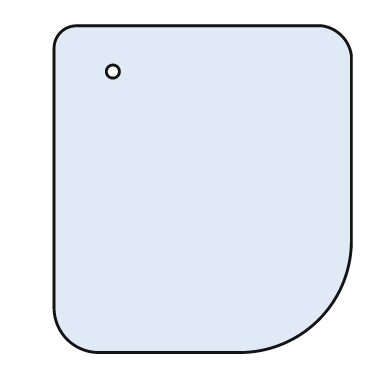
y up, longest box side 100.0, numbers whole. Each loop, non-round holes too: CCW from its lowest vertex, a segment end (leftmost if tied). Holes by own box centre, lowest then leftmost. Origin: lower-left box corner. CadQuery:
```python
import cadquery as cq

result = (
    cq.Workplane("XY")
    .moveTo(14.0, 0.0)
    .lineTo(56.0, 0.0)
    .threePointArc((81.0, 10.0), (91.0, 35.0))
    .lineTo(91.0, 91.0)
    .threePointArc((88.0, 97.0), (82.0, 100.0))
    .lineTo(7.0, 100.0)
    .threePointArc((2.0, 98.0), (0.0, 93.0))
    .lineTo(0.0, 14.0)
    .threePointArc((4.0, 4.0), (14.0, 0.0))
    .close()
    .moveTo(18.0, 86.0)
    .circle(2.0)
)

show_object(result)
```